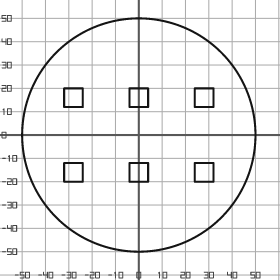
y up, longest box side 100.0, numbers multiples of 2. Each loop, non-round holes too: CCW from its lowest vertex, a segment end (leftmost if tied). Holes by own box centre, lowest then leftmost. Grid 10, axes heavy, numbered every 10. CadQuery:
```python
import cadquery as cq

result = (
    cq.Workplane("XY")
    .moveTo(0.0, 0.0)
    .circle(50.0)
    .moveTo(-32.0, -20.0)
    .lineTo(-24.0, -20.0)
    .lineTo(-24.0, -12.0)
    .lineTo(-32.0, -12.0)
    .close()
    .moveTo(-4.0, -20.0)
    .lineTo(4.0, -20.0)
    .lineTo(4.0, -12.0)
    .lineTo(-4.0, -12.0)
    .close()
    .moveTo(24.0, -20.0)
    .lineTo(32.0, -20.0)
    .lineTo(32.0, -12.0)
    .lineTo(24.0, -12.0)
    .close()
    .moveTo(-32.0, 12.0)
    .lineTo(-24.0, 12.0)
    .lineTo(-24.0, 20.0)
    .lineTo(-32.0, 20.0)
    .close()
    .moveTo(-4.0, 12.0)
    .lineTo(4.0, 12.0)
    .lineTo(4.0, 20.0)
    .lineTo(-4.0, 20.0)
    .close()
    .moveTo(24.0, 12.0)
    .lineTo(32.0, 12.0)
    .lineTo(32.0, 20.0)
    .lineTo(24.0, 20.0)
    .close()
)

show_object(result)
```